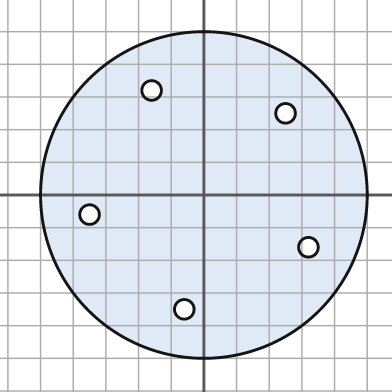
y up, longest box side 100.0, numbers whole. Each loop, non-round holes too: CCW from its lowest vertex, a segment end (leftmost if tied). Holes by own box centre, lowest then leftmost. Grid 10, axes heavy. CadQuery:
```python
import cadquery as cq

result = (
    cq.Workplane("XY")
    .moveTo(0.0, 0.0)
    .circle(50.0)
    .moveTo(-6.0, -35.0)
    .circle(3.0)
    .moveTo(32.0, -16.0)
    .circle(3.0)
    .moveTo(-35.0, -6.0)
    .circle(3.0)
    .moveTo(25.0, 25.0)
    .circle(3.0)
    .moveTo(-16.0, 32.0)
    .circle(3.0)
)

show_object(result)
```